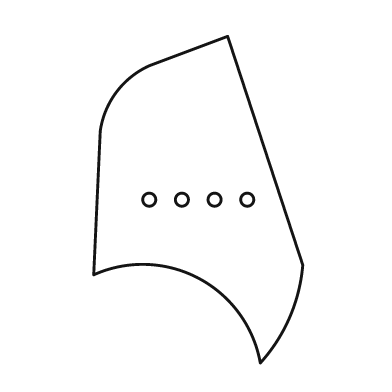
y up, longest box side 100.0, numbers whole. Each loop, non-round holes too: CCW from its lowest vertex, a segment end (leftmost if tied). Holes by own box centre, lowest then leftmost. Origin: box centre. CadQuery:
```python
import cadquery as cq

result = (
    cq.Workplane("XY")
    .moveTo(19.0, -50.0)
    .threePointArc((28.0, -36.0), (32.0, -20.0))
    .lineTo(9.0, 50.0)
    .lineTo(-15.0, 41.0)
    .threePointArc((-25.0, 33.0), (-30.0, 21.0))
    .lineTo(-32.0, -23.0)
    .threePointArc((0.0, -24.0), (19.0, -50.0))
    .close()
    .moveTo(-15.0, 0.0)
    .circle(2.0)
    .moveTo(-5.0, 0.0)
    .circle(2.0)
    .moveTo(5.0, 0.0)
    .circle(2.0)
    .moveTo(15.0, 0.0)
    .circle(2.0)
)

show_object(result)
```